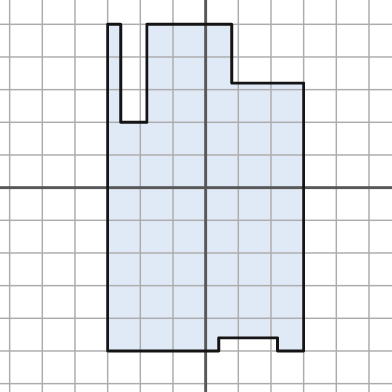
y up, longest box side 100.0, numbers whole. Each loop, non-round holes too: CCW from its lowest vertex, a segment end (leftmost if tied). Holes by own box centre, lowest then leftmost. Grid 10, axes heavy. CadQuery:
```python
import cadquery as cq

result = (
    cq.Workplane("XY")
    .moveTo(-30.0, -50.0)
    .lineTo(4.0, -50.0)
    .lineTo(4.0, -46.0)
    .lineTo(22.0, -46.0)
    .lineTo(22.0, -50.0)
    .lineTo(30.0, -50.0)
    .lineTo(30.0, 32.0)
    .lineTo(8.0, 32.0)
    .lineTo(8.0, 50.0)
    .lineTo(-18.0, 50.0)
    .lineTo(-18.0, 20.0)
    .lineTo(-26.0, 20.0)
    .lineTo(-26.0, 50.0)
    .lineTo(-30.0, 50.0)
    .close()
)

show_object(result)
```